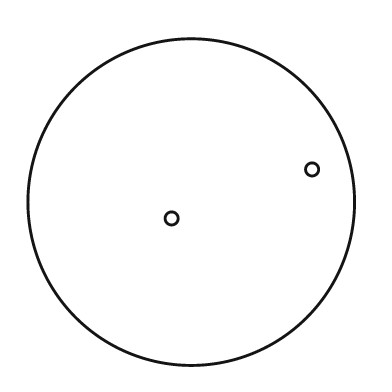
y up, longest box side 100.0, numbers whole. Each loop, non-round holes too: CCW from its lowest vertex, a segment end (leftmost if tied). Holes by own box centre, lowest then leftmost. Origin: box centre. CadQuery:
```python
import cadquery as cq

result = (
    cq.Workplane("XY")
    .moveTo(0.0, 0.0)
    .circle(50.0)
    .moveTo(-6.0, -5.0)
    .circle(2.0)
    .moveTo(37.0, 10.0)
    .circle(2.0)
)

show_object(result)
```